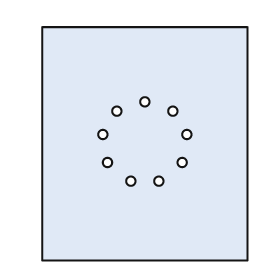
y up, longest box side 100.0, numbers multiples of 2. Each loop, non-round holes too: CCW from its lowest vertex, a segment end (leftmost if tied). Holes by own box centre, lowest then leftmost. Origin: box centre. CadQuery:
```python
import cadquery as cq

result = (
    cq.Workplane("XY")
    .moveTo(-44.0, -50.0)
    .lineTo(44.0, -50.0)
    .lineTo(44.0, 50.0)
    .lineTo(-44.0, 50.0)
    .close()
    .moveTo(-6.0, -16.0)
    .circle(2.0)
    .moveTo(6.0, -16.0)
    .circle(2.0)
    .moveTo(-16.0, -8.0)
    .circle(2.0)
    .moveTo(16.0, -8.0)
    .circle(2.0)
    .moveTo(-18.0, 4.0)
    .circle(2.0)
    .moveTo(18.0, 4.0)
    .circle(2.0)
    .moveTo(-12.0, 14.0)
    .circle(2.0)
    .moveTo(12.0, 14.0)
    .circle(2.0)
    .moveTo(0.0, 18.0)
    .circle(2.0)
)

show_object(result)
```